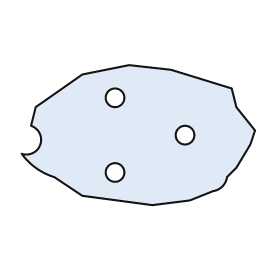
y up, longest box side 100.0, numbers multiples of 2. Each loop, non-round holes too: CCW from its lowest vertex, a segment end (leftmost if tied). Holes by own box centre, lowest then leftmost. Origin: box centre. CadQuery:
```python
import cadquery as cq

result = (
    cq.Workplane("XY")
    .moveTo(6.0, -30.0)
    .lineTo(22.0, -28.0)
    .lineTo(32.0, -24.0)
    .threePointArc((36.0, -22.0), (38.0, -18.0))
    .lineTo(42.0, -14.0)
    .lineTo(48.0, -4.0)
    .lineTo(50.0, 2.0)
    .lineTo(42.0, 12.0)
    .lineTo(40.0, 20.0)
    .lineTo(14.0, 28.0)
    .lineTo(-4.0, 30.0)
    .lineTo(-24.0, 26.0)
    .lineTo(-44.0, 12.0)
    .lineTo(-46.0, 4.0)
    .threePointArc((-42.0, -4.0), (-50.0, -8.0))
    .threePointArc((-44.0, -14.0), (-36.0, -18.0))
    .lineTo(-24.0, -26.0)
    .close()
    .moveTo(-10.0, -16.0)
    .circle(4.0)
    .moveTo(20.0, 0.0)
    .circle(4.0)
    .moveTo(-10.0, 16.0)
    .circle(4.0)
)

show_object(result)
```